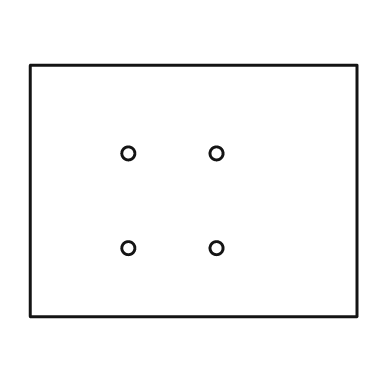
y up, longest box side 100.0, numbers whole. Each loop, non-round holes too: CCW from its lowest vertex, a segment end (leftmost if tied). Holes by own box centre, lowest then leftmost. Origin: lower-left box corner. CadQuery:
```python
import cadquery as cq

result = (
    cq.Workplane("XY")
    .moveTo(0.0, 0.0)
    .lineTo(100.0, 0.0)
    .lineTo(100.0, 77.0)
    .lineTo(0.0, 77.0)
    .close()
    .moveTo(30.0, 21.0)
    .circle(2.0)
    .moveTo(57.0, 21.0)
    .circle(2.0)
    .moveTo(30.0, 50.0)
    .circle(2.0)
    .moveTo(57.0, 50.0)
    .circle(2.0)
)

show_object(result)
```